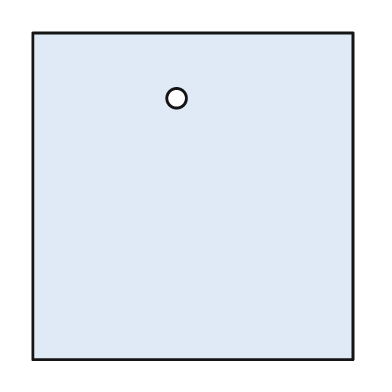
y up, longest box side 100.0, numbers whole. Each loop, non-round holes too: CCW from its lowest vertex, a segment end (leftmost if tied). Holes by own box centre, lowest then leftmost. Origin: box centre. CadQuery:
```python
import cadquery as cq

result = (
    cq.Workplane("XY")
    .moveTo(-49.0, -50.0)
    .lineTo(49.0, -50.0)
    .lineTo(49.0, 50.0)
    .lineTo(-49.0, 50.0)
    .close()
    .moveTo(-5.0, 30.0)
    .circle(3.0)
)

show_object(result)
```